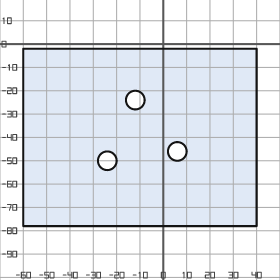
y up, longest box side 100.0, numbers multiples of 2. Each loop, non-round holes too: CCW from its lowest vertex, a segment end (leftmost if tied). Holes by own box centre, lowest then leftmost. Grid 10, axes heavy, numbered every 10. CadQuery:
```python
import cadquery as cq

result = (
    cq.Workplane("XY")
    .moveTo(-60.0, -78.0)
    .lineTo(40.0, -78.0)
    .lineTo(40.0, -2.0)
    .lineTo(-60.0, -2.0)
    .close()
    .moveTo(-24.0, -50.0)
    .circle(4.0)
    .moveTo(6.0, -46.0)
    .circle(4.0)
    .moveTo(-12.0, -24.0)
    .circle(4.0)
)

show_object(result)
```